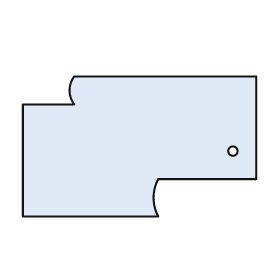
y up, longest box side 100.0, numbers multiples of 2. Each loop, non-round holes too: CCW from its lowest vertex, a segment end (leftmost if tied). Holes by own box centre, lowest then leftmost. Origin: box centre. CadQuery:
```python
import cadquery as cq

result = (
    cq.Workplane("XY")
    .moveTo(-50.0, -30.0)
    .lineTo(8.0, -30.0)
    .threePointArc((6.0, -22.0), (8.0, -14.0))
    .lineTo(50.0, -14.0)
    .lineTo(50.0, 30.0)
    .lineTo(-28.0, 30.0)
    .threePointArc((-30.0, 24.0), (-28.0, 18.0))
    .lineTo(-50.0, 18.0)
    .close()
    .moveTo(40.0, -2.0)
    .circle(2.0)
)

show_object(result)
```